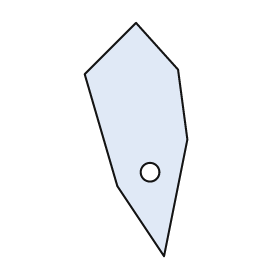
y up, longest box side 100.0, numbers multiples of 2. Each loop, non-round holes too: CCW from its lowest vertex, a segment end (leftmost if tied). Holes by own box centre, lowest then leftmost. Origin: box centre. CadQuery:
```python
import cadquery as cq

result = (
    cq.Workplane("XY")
    .moveTo(12.0, -50.0)
    .lineTo(22.0, 0.0)
    .lineTo(18.0, 30.0)
    .lineTo(0.0, 50.0)
    .lineTo(-22.0, 28.0)
    .lineTo(-8.0, -20.0)
    .close()
    .moveTo(6.0, -14.0)
    .circle(4.0)
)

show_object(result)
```